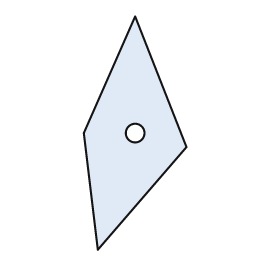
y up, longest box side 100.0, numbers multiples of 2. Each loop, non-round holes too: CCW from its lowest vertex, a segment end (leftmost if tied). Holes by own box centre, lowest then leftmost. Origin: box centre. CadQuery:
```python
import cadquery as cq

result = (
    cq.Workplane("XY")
    .moveTo(-16.0, -50.0)
    .lineTo(22.0, -6.0)
    .lineTo(0.0, 50.0)
    .lineTo(-22.0, 0.0)
    .close()
    .moveTo(0.0, 0.0)
    .circle(4.0)
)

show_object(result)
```